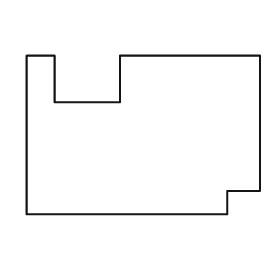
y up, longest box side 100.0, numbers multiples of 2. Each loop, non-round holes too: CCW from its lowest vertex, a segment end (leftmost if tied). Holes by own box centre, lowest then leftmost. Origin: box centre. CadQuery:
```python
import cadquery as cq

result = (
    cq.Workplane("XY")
    .moveTo(-50.0, -34.0)
    .lineTo(36.0, -34.0)
    .lineTo(36.0, -24.0)
    .lineTo(50.0, -24.0)
    .lineTo(50.0, 34.0)
    .lineTo(-10.0, 34.0)
    .lineTo(-10.0, 14.0)
    .lineTo(-38.0, 14.0)
    .lineTo(-38.0, 34.0)
    .lineTo(-50.0, 34.0)
    .close()
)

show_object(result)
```